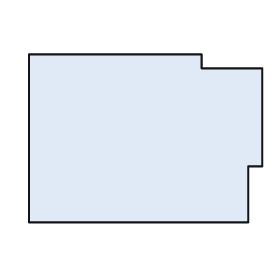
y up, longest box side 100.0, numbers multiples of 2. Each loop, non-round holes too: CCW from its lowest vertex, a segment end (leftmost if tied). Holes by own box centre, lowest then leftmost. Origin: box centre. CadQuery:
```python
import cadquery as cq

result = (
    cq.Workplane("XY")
    .moveTo(-50.0, -36.0)
    .lineTo(44.0, -36.0)
    .lineTo(44.0, -12.0)
    .lineTo(50.0, -12.0)
    .lineTo(50.0, 30.0)
    .lineTo(24.0, 30.0)
    .lineTo(24.0, 36.0)
    .lineTo(-50.0, 36.0)
    .close()
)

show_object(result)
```